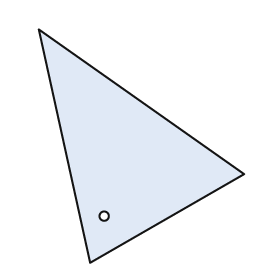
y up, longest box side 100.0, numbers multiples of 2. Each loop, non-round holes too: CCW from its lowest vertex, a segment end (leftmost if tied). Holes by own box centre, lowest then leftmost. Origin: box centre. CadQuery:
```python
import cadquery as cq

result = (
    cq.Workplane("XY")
    .moveTo(-22.0, -50.0)
    .lineTo(44.0, -12.0)
    .lineTo(-44.0, 50.0)
    .close()
    .moveTo(-16.0, -30.0)
    .circle(2.0)
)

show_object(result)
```